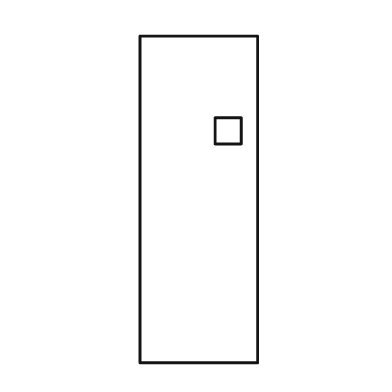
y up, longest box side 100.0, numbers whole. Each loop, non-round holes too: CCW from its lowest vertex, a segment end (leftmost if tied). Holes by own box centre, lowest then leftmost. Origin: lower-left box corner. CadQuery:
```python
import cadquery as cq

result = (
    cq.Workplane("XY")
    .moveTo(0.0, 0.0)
    .lineTo(36.0, 0.0)
    .lineTo(36.0, 100.0)
    .lineTo(0.0, 100.0)
    .close()
    .moveTo(23.0, 67.0)
    .lineTo(31.0, 67.0)
    .lineTo(31.0, 75.0)
    .lineTo(23.0, 75.0)
    .close()
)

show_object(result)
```